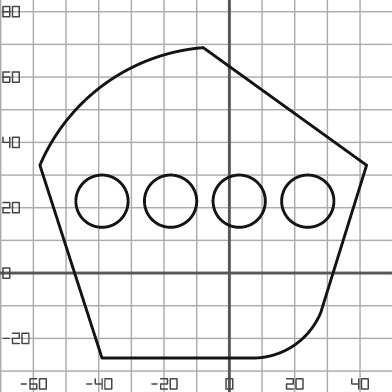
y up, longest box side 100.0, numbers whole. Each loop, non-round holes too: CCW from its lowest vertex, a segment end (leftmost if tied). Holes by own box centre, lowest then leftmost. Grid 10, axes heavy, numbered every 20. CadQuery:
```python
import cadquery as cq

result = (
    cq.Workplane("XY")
    .moveTo(-39.0, -26.0)
    .lineTo(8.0, -26.0)
    .threePointArc((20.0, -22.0), (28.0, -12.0))
    .lineTo(42.0, 33.0)
    .lineTo(-8.0, 69.0)
    .threePointArc((-38.0, 58.0), (-58.0, 33.0))
    .close()
    .moveTo(-39.0, 22.0)
    .circle(8.0)
    .moveTo(-18.0, 22.0)
    .circle(8.0)
    .moveTo(3.0, 22.0)
    .circle(8.0)
    .moveTo(24.0, 22.0)
    .circle(8.0)
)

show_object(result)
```